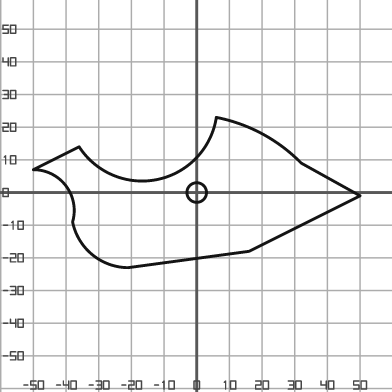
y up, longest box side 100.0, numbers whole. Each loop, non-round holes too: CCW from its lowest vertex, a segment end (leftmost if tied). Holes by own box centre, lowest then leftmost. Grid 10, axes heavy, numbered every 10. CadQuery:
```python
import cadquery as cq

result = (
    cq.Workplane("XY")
    .moveTo(-21.0, -23.0)
    .lineTo(16.0, -18.0)
    .lineTo(50.0, -1.0)
    .lineTo(32.0, 9.0)
    .threePointArc((20.0, 18.0), (6.0, 23.0))
    .threePointArc((-12.0, 4.0), (-36.0, 14.0))
    .lineTo(-50.0, 7.0)
    .threePointArc((-40.0, 2.0), (-38.0, -9.0))
    .threePointArc((-32.0, -19.0), (-21.0, -23.0))
    .close()
    .moveTo(0.0, 0.0)
    .circle(3.0)
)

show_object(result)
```